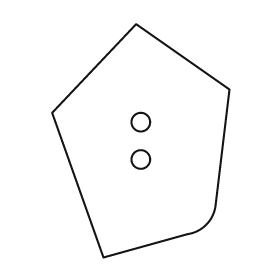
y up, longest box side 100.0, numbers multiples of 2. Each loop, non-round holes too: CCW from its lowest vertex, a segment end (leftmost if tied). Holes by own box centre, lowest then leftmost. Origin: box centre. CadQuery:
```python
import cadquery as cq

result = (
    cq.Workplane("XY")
    .moveTo(-16.0, -50.0)
    .lineTo(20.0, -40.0)
    .threePointArc((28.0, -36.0), (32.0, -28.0))
    .lineTo(38.0, 22.0)
    .lineTo(-2.0, 50.0)
    .lineTo(-38.0, 12.0)
    .close()
    .moveTo(0.0, -8.0)
    .circle(4.0)
    .moveTo(0.0, 8.0)
    .circle(4.0)
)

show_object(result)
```